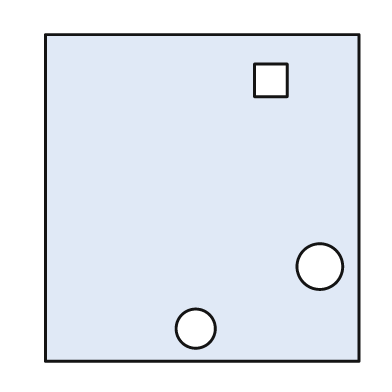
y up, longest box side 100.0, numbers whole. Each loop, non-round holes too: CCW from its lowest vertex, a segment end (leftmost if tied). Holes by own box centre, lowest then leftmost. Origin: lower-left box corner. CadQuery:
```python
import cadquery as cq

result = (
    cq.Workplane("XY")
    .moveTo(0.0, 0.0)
    .lineTo(96.0, 0.0)
    .lineTo(96.0, 100.0)
    .lineTo(0.0, 100.0)
    .close()
    .moveTo(46.0, 10.0)
    .circle(6.0)
    .moveTo(84.0, 29.0)
    .circle(7.0)
    .moveTo(64.0, 81.0)
    .lineTo(74.0, 81.0)
    .lineTo(74.0, 91.0)
    .lineTo(64.0, 91.0)
    .close()
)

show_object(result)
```